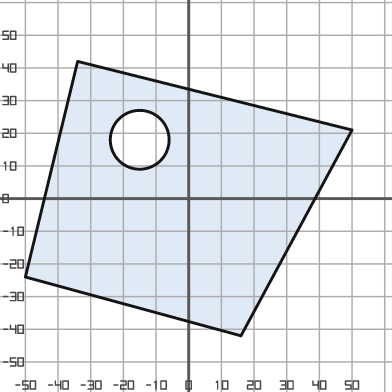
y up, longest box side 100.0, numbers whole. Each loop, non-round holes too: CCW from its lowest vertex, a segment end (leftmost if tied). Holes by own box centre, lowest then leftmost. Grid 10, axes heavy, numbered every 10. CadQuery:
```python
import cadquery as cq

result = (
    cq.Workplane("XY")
    .moveTo(16.0, -42.0)
    .lineTo(50.0, 21.0)
    .lineTo(-34.0, 42.0)
    .lineTo(-50.0, -24.0)
    .close()
    .moveTo(-15.0, 18.0)
    .circle(9.0)
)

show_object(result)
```